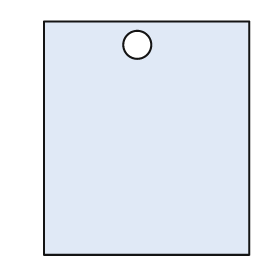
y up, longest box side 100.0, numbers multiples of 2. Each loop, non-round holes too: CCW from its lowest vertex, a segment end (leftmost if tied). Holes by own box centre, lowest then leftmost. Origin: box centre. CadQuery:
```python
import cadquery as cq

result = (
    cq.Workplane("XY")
    .moveTo(-44.0, -50.0)
    .lineTo(44.0, -50.0)
    .lineTo(44.0, 50.0)
    .lineTo(-44.0, 50.0)
    .close()
    .moveTo(-4.0, 40.0)
    .circle(6.0)
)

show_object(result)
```